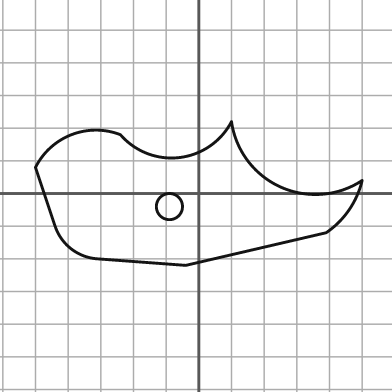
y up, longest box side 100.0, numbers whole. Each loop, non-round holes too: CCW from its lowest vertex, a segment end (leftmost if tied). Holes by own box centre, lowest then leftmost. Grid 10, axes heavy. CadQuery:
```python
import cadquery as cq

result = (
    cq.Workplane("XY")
    .moveTo(-4.0, -22.0)
    .lineTo(39.0, -12.0)
    .threePointArc((46.0, -5.0), (50.0, 4.0))
    .threePointArc((25.0, 2.0), (10.0, 22.0))
    .threePointArc((-6.0, 11.0), (-24.0, 18.0))
    .threePointArc((-39.0, 18.0), (-50.0, 8.0))
    .lineTo(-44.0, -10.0)
    .threePointArc((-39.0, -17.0), (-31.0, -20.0))
    .close()
    .moveTo(-9.0, -4.0)
    .circle(4.0)
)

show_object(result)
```